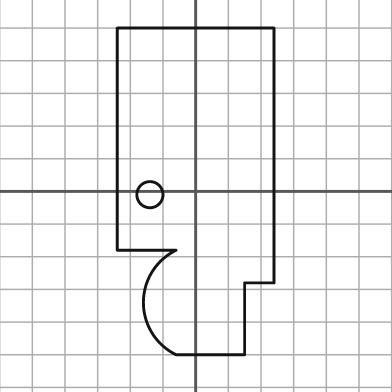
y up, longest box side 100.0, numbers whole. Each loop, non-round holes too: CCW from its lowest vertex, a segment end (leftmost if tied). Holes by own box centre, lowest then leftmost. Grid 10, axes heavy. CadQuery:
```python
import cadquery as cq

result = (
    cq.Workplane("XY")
    .moveTo(-6.0, -50.0)
    .lineTo(15.0, -50.0)
    .lineTo(15.0, -28.0)
    .lineTo(24.0, -28.0)
    .lineTo(24.0, 50.0)
    .lineTo(-24.0, 50.0)
    .lineTo(-24.0, -18.0)
    .lineTo(-6.0, -18.0)
    .threePointArc((-16.0, -34.0), (-6.0, -50.0))
    .close()
    .moveTo(-14.0, -1.0)
    .circle(4.0)
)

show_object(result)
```